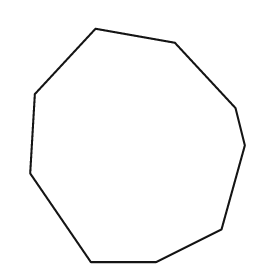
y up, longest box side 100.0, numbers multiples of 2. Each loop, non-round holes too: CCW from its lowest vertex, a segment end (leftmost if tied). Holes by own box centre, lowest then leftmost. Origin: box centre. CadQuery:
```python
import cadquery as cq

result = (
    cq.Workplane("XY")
    .moveTo(-20.0, -50.0)
    .lineTo(8.0, -50.0)
    .lineTo(36.0, -36.0)
    .lineTo(46.0, 0.0)
    .lineTo(42.0, 16.0)
    .lineTo(16.0, 44.0)
    .lineTo(-18.0, 50.0)
    .lineTo(-44.0, 22.0)
    .lineTo(-46.0, -12.0)
    .close()
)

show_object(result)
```